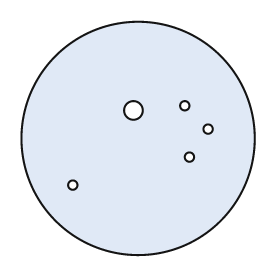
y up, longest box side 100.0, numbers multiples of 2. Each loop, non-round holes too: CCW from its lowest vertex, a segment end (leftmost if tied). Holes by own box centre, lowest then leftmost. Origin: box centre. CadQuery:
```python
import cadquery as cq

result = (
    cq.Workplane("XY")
    .moveTo(0.0, 0.0)
    .circle(50.0)
    .moveTo(-28.0, -20.0)
    .circle(2.0)
    .moveTo(22.0, -8.0)
    .circle(2.0)
    .moveTo(30.0, 4.0)
    .circle(2.0)
    .moveTo(-2.0, 12.0)
    .circle(4.0)
    .moveTo(20.0, 14.0)
    .circle(2.0)
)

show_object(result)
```